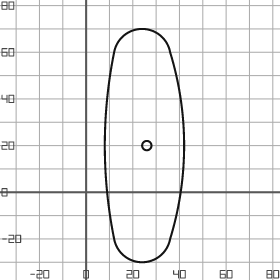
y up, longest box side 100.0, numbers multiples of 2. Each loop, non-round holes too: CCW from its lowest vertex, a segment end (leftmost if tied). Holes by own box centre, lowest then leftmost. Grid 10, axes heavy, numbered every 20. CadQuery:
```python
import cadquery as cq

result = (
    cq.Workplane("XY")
    .moveTo(12.0, -20.0)
    .threePointArc((24.0, -30.0), (36.0, -20.0))
    .threePointArc((42.0, 20.0), (36.0, 60.0))
    .threePointArc((24.0, 70.0), (12.0, 60.0))
    .threePointArc((8.0, 20.0), (12.0, -20.0))
    .close()
    .moveTo(26.0, 20.0)
    .circle(2.0)
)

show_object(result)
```